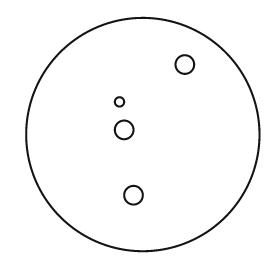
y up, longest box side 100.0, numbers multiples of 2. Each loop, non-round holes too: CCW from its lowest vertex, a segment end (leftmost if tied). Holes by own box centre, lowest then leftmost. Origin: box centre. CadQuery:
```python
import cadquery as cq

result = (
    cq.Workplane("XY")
    .moveTo(0.0, 0.0)
    .circle(50.0)
    .moveTo(-4.0, -26.0)
    .circle(4.0)
    .moveTo(-8.0, 2.0)
    .circle(4.0)
    .moveTo(-10.0, 14.0)
    .circle(2.0)
    .moveTo(18.0, 30.0)
    .circle(4.0)
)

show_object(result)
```